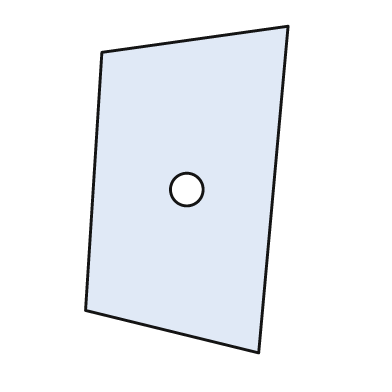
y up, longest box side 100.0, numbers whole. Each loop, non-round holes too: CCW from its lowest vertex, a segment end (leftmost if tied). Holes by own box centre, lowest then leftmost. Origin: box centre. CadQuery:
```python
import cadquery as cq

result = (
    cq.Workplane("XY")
    .moveTo(22.0, -50.0)
    .lineTo(31.0, 50.0)
    .lineTo(-26.0, 42.0)
    .lineTo(-31.0, -37.0)
    .close()
    .moveTo(0.0, 0.0)
    .circle(5.0)
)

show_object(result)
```